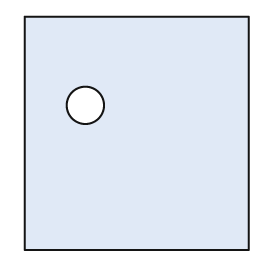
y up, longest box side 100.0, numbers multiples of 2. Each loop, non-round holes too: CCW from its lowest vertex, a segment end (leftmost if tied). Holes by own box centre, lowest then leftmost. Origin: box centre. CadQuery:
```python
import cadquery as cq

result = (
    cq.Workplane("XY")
    .moveTo(-48.0, -50.0)
    .lineTo(48.0, -50.0)
    .lineTo(48.0, 50.0)
    .lineTo(-48.0, 50.0)
    .close()
    .moveTo(-22.0, 12.0)
    .circle(8.0)
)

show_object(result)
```